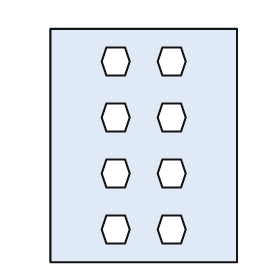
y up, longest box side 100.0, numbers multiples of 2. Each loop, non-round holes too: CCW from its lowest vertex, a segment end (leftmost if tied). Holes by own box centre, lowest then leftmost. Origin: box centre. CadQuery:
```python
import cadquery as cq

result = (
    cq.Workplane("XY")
    .moveTo(-40.0, -50.0)
    .lineTo(40.0, -50.0)
    .lineTo(40.0, 50.0)
    .lineTo(-40.0, 50.0)
    .close()
    .moveTo(-16.0, -42.0)
    .lineTo(-8.0, -42.0)
    .lineTo(-6.0, -36.0)
    .lineTo(-8.0, -30.0)
    .lineTo(-16.0, -30.0)
    .lineTo(-18.0, -36.0)
    .close()
    .moveTo(8.0, -42.0)
    .lineTo(16.0, -42.0)
    .lineTo(18.0, -36.0)
    .lineTo(16.0, -30.0)
    .lineTo(8.0, -30.0)
    .lineTo(6.0, -36.0)
    .close()
    .moveTo(-16.0, -18.0)
    .lineTo(-8.0, -18.0)
    .lineTo(-6.0, -12.0)
    .lineTo(-8.0, -6.0)
    .lineTo(-16.0, -6.0)
    .lineTo(-18.0, -12.0)
    .close()
    .moveTo(8.0, -18.0)
    .lineTo(16.0, -18.0)
    .lineTo(18.0, -12.0)
    .lineTo(16.0, -6.0)
    .lineTo(8.0, -6.0)
    .lineTo(6.0, -12.0)
    .close()
    .moveTo(-16.0, 6.0)
    .lineTo(-8.0, 6.0)
    .lineTo(-6.0, 12.0)
    .lineTo(-8.0, 18.0)
    .lineTo(-16.0, 18.0)
    .lineTo(-18.0, 12.0)
    .close()
    .moveTo(8.0, 6.0)
    .lineTo(16.0, 6.0)
    .lineTo(18.0, 12.0)
    .lineTo(16.0, 18.0)
    .lineTo(8.0, 18.0)
    .lineTo(6.0, 12.0)
    .close()
    .moveTo(-16.0, 30.0)
    .lineTo(-8.0, 30.0)
    .lineTo(-6.0, 36.0)
    .lineTo(-8.0, 42.0)
    .lineTo(-16.0, 42.0)
    .lineTo(-18.0, 36.0)
    .close()
    .moveTo(8.0, 30.0)
    .lineTo(16.0, 30.0)
    .lineTo(18.0, 36.0)
    .lineTo(16.0, 42.0)
    .lineTo(8.0, 42.0)
    .lineTo(6.0, 36.0)
    .close()
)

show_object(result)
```